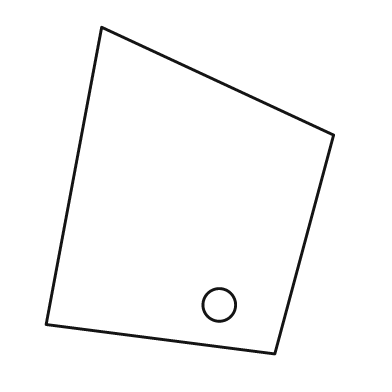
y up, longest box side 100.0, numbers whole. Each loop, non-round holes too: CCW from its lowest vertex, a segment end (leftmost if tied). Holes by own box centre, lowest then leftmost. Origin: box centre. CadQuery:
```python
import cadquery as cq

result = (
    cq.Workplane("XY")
    .moveTo(26.0, -50.0)
    .lineTo(44.0, 17.0)
    .lineTo(-27.0, 50.0)
    .lineTo(-44.0, -41.0)
    .close()
    .moveTo(9.0, -35.0)
    .circle(5.0)
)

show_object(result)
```